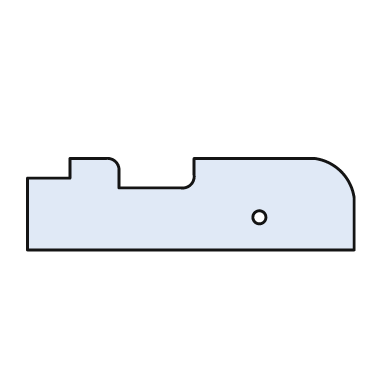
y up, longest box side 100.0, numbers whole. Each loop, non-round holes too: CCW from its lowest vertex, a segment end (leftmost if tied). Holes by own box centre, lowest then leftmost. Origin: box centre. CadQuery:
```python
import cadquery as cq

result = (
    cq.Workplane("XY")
    .moveTo(-50.0, -14.0)
    .lineTo(50.0, -14.0)
    .lineTo(50.0, 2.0)
    .threePointArc((46.0, 10.0), (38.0, 14.0))
    .lineTo(1.0, 14.0)
    .lineTo(1.0, 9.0)
    .threePointArc((0.0, 6.0), (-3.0, 5.0))
    .lineTo(-22.0, 5.0)
    .lineTo(-22.0, 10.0)
    .threePointArc((-23.0, 13.0), (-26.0, 14.0))
    .lineTo(-37.0, 14.0)
    .lineTo(-37.0, 8.0)
    .lineTo(-50.0, 8.0)
    .close()
    .moveTo(21.0, -4.0)
    .circle(2.0)
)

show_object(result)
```